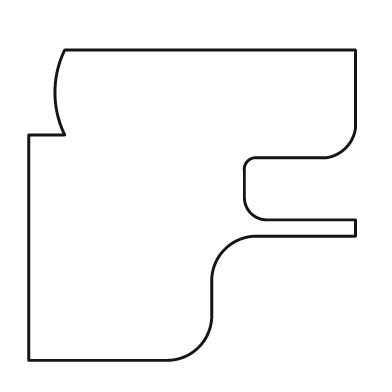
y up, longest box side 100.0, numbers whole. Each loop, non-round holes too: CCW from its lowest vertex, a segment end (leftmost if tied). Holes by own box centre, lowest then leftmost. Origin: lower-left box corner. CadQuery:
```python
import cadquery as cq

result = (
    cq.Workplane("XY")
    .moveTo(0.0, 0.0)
    .lineTo(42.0, 0.0)
    .threePointArc((52.0, 4.0), (56.0, 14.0))
    .lineTo(56.0, 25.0)
    .threePointArc((60.0, 34.0), (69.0, 38.0))
    .lineTo(100.0, 38.0)
    .lineTo(100.0, 43.0)
    .lineTo(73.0, 43.0)
    .threePointArc((68.0, 45.0), (66.0, 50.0))
    .lineTo(66.0, 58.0)
    .threePointArc((67.0, 61.0), (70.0, 62.0))
    .lineTo(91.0, 62.0)
    .threePointArc((97.0, 65.0), (100.0, 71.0))
    .lineTo(100.0, 95.0)
    .lineTo(11.0, 95.0)
    .threePointArc((8.0, 82.0), (11.0, 69.0))
    .lineTo(0.0, 69.0)
    .close()
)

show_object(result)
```